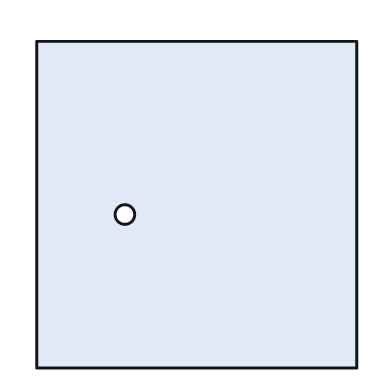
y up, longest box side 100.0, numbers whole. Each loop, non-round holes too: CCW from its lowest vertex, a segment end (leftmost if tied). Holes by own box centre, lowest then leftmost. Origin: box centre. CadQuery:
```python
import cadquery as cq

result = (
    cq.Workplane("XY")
    .moveTo(-49.0, -50.0)
    .lineTo(49.0, -50.0)
    .lineTo(49.0, 50.0)
    .lineTo(-49.0, 50.0)
    .close()
    .moveTo(-22.0, -3.0)
    .circle(3.0)
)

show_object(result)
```